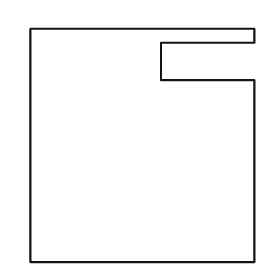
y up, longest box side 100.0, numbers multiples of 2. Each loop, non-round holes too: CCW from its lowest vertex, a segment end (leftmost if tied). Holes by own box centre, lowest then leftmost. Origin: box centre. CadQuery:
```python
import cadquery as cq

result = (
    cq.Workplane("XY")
    .moveTo(-48.0, -50.0)
    .lineTo(48.0, -50.0)
    .lineTo(48.0, 28.0)
    .lineTo(8.0, 28.0)
    .lineTo(8.0, 44.0)
    .lineTo(48.0, 44.0)
    .lineTo(48.0, 50.0)
    .lineTo(-48.0, 50.0)
    .close()
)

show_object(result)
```